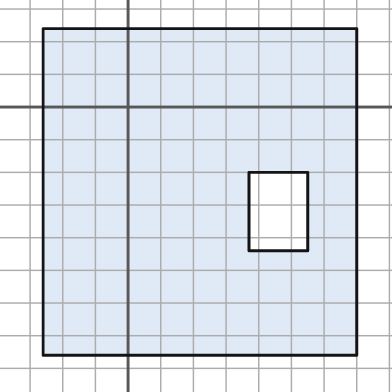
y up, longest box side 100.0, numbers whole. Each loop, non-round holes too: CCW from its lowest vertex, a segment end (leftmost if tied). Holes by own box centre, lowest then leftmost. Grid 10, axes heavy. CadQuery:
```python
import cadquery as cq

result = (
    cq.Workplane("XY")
    .moveTo(-26.0, -76.0)
    .lineTo(70.0, -76.0)
    .lineTo(70.0, 24.0)
    .lineTo(-26.0, 24.0)
    .close()
    .moveTo(37.0, -44.0)
    .lineTo(55.0, -44.0)
    .lineTo(55.0, -20.0)
    .lineTo(37.0, -20.0)
    .close()
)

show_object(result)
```